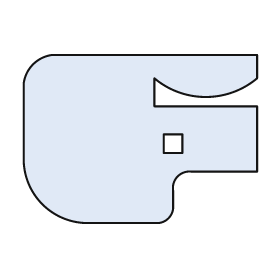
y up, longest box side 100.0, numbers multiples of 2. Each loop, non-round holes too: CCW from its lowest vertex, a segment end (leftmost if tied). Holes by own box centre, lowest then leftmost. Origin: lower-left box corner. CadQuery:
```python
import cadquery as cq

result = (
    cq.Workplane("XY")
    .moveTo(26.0, 0.0)
    .lineTo(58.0, 0.0)
    .threePointArc((62.0, 2.0), (64.0, 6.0))
    .lineTo(64.0, 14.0)
    .threePointArc((66.0, 20.0), (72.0, 22.0))
    .lineTo(100.0, 22.0)
    .lineTo(100.0, 50.0)
    .lineTo(56.0, 50.0)
    .lineTo(56.0, 62.0)
    .threePointArc((78.0, 54.0), (100.0, 62.0))
    .lineTo(100.0, 72.0)
    .lineTo(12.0, 72.0)
    .threePointArc((4.0, 68.0), (0.0, 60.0))
    .lineTo(0.0, 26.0)
    .threePointArc((8.0, 8.0), (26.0, 0.0))
    .close()
    .moveTo(60.0, 30.0)
    .lineTo(68.0, 30.0)
    .lineTo(68.0, 38.0)
    .lineTo(60.0, 38.0)
    .close()
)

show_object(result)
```